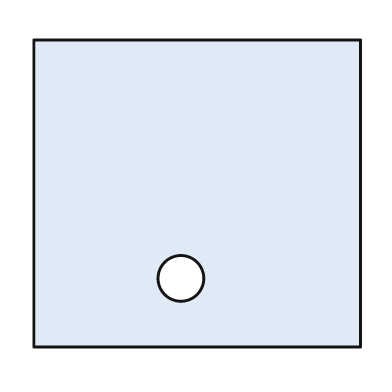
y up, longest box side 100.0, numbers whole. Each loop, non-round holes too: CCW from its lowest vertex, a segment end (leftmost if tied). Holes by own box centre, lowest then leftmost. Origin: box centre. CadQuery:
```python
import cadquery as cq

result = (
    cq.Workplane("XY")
    .moveTo(-50.0, -47.0)
    .lineTo(50.0, -47.0)
    .lineTo(50.0, 47.0)
    .lineTo(-50.0, 47.0)
    .close()
    .moveTo(-5.0, -26.0)
    .circle(7.0)
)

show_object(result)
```